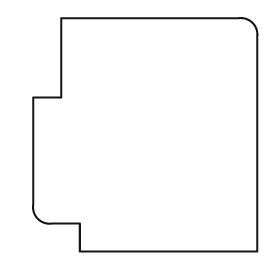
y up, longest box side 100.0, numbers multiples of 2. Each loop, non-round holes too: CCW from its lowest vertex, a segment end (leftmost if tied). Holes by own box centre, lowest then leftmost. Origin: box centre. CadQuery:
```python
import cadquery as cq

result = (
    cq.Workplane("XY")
    .moveTo(-28.0, -50.0)
    .lineTo(48.0, -50.0)
    .lineTo(48.0, 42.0)
    .threePointArc((46.0, 48.0), (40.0, 50.0))
    .lineTo(-36.0, 50.0)
    .lineTo(-36.0, 16.0)
    .lineTo(-48.0, 16.0)
    .lineTo(-48.0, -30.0)
    .threePointArc((-46.0, -36.0), (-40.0, -38.0))
    .lineTo(-28.0, -38.0)
    .close()
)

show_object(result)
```